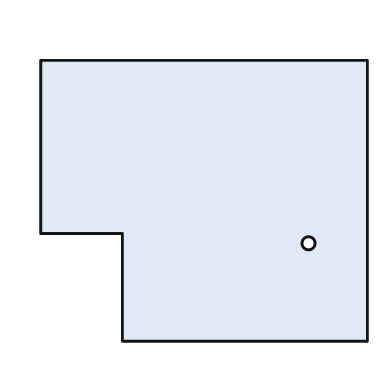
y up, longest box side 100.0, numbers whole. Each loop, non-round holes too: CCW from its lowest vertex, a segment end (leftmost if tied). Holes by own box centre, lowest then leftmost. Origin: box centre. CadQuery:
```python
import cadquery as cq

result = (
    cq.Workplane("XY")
    .moveTo(-25.0, -43.0)
    .lineTo(50.0, -43.0)
    .lineTo(50.0, 43.0)
    .lineTo(-50.0, 43.0)
    .lineTo(-50.0, -10.0)
    .lineTo(-25.0, -10.0)
    .close()
    .moveTo(32.0, -13.0)
    .circle(2.0)
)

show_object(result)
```